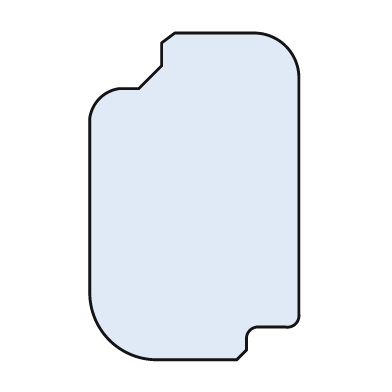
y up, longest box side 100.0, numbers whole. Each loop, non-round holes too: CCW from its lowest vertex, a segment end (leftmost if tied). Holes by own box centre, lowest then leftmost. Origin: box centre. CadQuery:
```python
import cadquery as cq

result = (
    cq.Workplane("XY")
    .moveTo(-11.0, -50.0)
    .lineTo(13.0, -50.0)
    .lineTo(16.0, -47.0)
    .lineTo(16.0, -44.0)
    .threePointArc((17.0, -41.0), (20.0, -40.0))
    .lineTo(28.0, -40.0)
    .threePointArc((31.0, -39.0), (32.0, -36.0))
    .lineTo(32.0, 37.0)
    .threePointArc((28.0, 46.0), (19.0, 50.0))
    .lineTo(-6.0, 50.0)
    .lineTo(-10.0, 47.0)
    .lineTo(-10.0, 40.0)
    .lineTo(-17.0, 33.0)
    .lineTo(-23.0, 33.0)
    .threePointArc((-29.0, 30.0), (-32.0, 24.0))
    .lineTo(-32.0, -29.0)
    .threePointArc((-26.0, -44.0), (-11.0, -50.0))
    .close()
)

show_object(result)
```